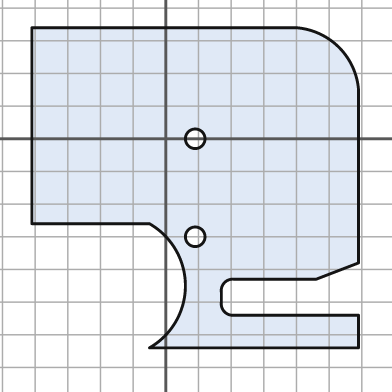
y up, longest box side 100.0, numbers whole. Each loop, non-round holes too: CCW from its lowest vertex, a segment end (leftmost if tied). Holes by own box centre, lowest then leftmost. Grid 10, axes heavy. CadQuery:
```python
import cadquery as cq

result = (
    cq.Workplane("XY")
    .moveTo(-5.0, -64.0)
    .lineTo(59.0, -64.0)
    .lineTo(59.0, -54.0)
    .lineTo(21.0, -54.0)
    .threePointArc((18.0, -53.0), (17.0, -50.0))
    .lineTo(17.0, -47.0)
    .threePointArc((18.0, -44.0), (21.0, -43.0))
    .lineTo(46.0, -43.0)
    .lineTo(59.0, -38.0)
    .lineTo(59.0, 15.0)
    .threePointArc((53.0, 28.0), (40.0, 34.0))
    .lineTo(-41.0, 34.0)
    .lineTo(-41.0, -26.0)
    .lineTo(-5.0, -26.0)
    .threePointArc((6.0, -45.0), (-5.0, -64.0))
    .close()
    .moveTo(9.0, -30.0)
    .circle(3.0)
    .moveTo(9.0, 0.0)
    .circle(3.0)
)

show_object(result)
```